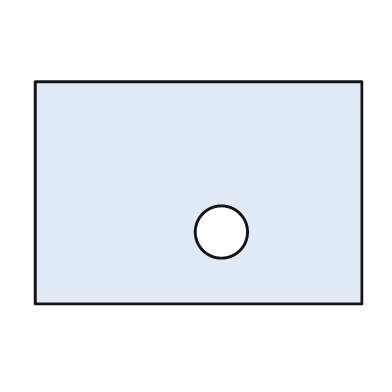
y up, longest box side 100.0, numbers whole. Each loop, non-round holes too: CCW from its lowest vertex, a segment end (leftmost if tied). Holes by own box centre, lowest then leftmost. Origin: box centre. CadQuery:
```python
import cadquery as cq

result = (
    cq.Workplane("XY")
    .moveTo(-50.0, -34.0)
    .lineTo(50.0, -34.0)
    .lineTo(50.0, 34.0)
    .lineTo(-50.0, 34.0)
    .close()
    .moveTo(7.0, -12.0)
    .circle(8.0)
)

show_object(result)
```